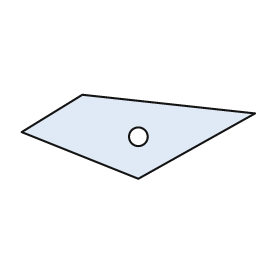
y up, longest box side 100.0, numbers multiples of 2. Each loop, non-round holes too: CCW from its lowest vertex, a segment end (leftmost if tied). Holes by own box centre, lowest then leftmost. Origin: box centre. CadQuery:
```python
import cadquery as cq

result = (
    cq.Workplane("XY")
    .moveTo(0.0, -18.0)
    .lineTo(50.0, 10.0)
    .lineTo(-24.0, 18.0)
    .lineTo(-50.0, 2.0)
    .close()
    .moveTo(0.0, 0.0)
    .circle(4.0)
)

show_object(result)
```